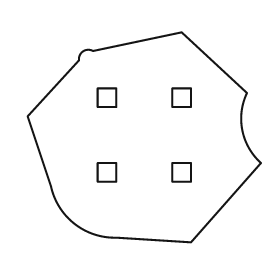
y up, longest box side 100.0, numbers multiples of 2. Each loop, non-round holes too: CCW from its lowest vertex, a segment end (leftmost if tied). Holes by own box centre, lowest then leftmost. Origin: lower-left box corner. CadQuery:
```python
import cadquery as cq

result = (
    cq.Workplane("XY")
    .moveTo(70.0, 0.0)
    .lineTo(100.0, 34.0)
    .threePointArc((92.0, 48.0), (94.0, 64.0))
    .lineTo(66.0, 90.0)
    .lineTo(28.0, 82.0)
    .threePointArc((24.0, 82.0), (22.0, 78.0))
    .lineTo(0.0, 54.0)
    .lineTo(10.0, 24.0)
    .threePointArc((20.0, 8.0), (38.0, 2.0))
    .close()
    .moveTo(30.0, 26.0)
    .lineTo(38.0, 26.0)
    .lineTo(38.0, 34.0)
    .lineTo(30.0, 34.0)
    .close()
    .moveTo(62.0, 26.0)
    .lineTo(70.0, 26.0)
    .lineTo(70.0, 34.0)
    .lineTo(62.0, 34.0)
    .close()
    .moveTo(30.0, 58.0)
    .lineTo(38.0, 58.0)
    .lineTo(38.0, 66.0)
    .lineTo(30.0, 66.0)
    .close()
    .moveTo(62.0, 58.0)
    .lineTo(70.0, 58.0)
    .lineTo(70.0, 66.0)
    .lineTo(62.0, 66.0)
    .close()
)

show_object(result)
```